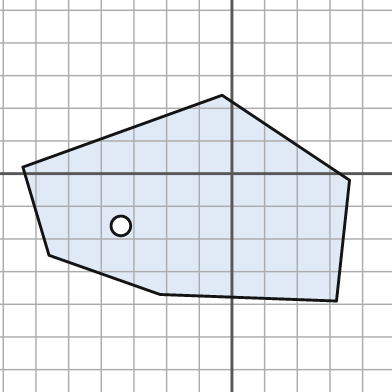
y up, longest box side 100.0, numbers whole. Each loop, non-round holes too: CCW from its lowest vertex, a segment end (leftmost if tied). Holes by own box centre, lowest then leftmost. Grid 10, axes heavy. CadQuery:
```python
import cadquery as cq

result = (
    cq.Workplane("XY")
    .moveTo(32.0, -39.0)
    .lineTo(36.0, -2.0)
    .lineTo(-3.0, 24.0)
    .lineTo(-64.0, 2.0)
    .lineTo(-56.0, -25.0)
    .lineTo(-22.0, -37.0)
    .close()
    .moveTo(-34.0, -16.0)
    .circle(3.0)
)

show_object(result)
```